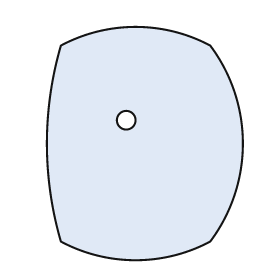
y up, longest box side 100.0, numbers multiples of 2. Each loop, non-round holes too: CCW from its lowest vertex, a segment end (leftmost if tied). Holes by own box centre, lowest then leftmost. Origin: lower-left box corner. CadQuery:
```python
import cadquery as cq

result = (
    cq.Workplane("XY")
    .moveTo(6.0, 8.0)
    .threePointArc((38.0, 0.0), (70.0, 8.0))
    .threePointArc((84.0, 50.0), (70.0, 92.0))
    .threePointArc((38.0, 100.0), (6.0, 92.0))
    .threePointArc((0.0, 50.0), (6.0, 8.0))
    .close()
    .moveTo(34.0, 60.0)
    .circle(4.0)
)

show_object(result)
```